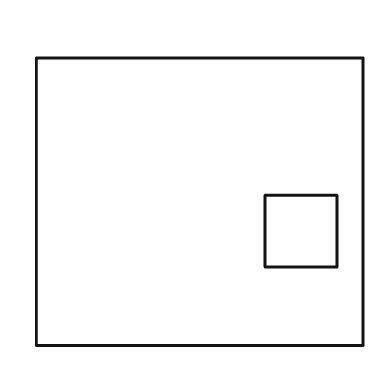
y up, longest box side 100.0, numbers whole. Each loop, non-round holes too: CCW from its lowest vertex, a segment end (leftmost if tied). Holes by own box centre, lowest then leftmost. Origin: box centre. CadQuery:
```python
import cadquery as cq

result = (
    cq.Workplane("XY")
    .moveTo(-50.0, -44.0)
    .lineTo(50.0, -44.0)
    .lineTo(50.0, 44.0)
    .lineTo(-50.0, 44.0)
    .close()
    .moveTo(20.0, -20.0)
    .lineTo(42.0, -20.0)
    .lineTo(42.0, 2.0)
    .lineTo(20.0, 2.0)
    .close()
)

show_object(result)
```